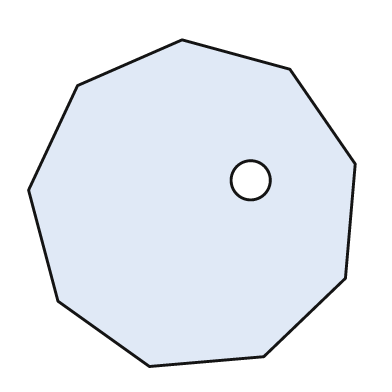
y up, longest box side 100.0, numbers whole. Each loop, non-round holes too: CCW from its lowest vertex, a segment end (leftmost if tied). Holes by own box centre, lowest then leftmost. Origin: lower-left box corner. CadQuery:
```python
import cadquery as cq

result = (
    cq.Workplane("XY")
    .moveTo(37.0, 0.0)
    .lineTo(72.0, 3.0)
    .lineTo(97.0, 27.0)
    .lineTo(100.0, 62.0)
    .lineTo(80.0, 91.0)
    .lineTo(47.0, 100.0)
    .lineTo(15.0, 86.0)
    .lineTo(0.0, 54.0)
    .lineTo(9.0, 20.0)
    .close()
    .moveTo(68.0, 57.0)
    .circle(6.0)
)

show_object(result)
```